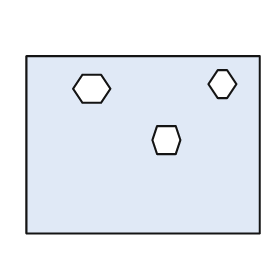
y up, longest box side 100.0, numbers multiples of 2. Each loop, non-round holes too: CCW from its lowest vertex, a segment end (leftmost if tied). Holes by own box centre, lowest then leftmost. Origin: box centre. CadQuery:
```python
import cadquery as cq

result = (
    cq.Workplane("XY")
    .moveTo(-50.0, -38.0)
    .lineTo(50.0, -38.0)
    .lineTo(50.0, 38.0)
    .lineTo(-50.0, 38.0)
    .close()
    .moveTo(6.0, -4.0)
    .lineTo(14.0, -4.0)
    .lineTo(16.0, 2.0)
    .lineTo(14.0, 8.0)
    .lineTo(6.0, 8.0)
    .lineTo(4.0, 2.0)
    .close()
    .moveTo(-26.0, 18.0)
    .lineTo(-18.0, 18.0)
    .lineTo(-14.0, 24.0)
    .lineTo(-18.0, 30.0)
    .lineTo(-26.0, 30.0)
    .lineTo(-30.0, 24.0)
    .close()
    .moveTo(32.0, 20.0)
    .lineTo(36.0, 20.0)
    .lineTo(40.0, 26.0)
    .lineTo(36.0, 32.0)
    .lineTo(32.0, 32.0)
    .lineTo(28.0, 26.0)
    .close()
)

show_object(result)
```